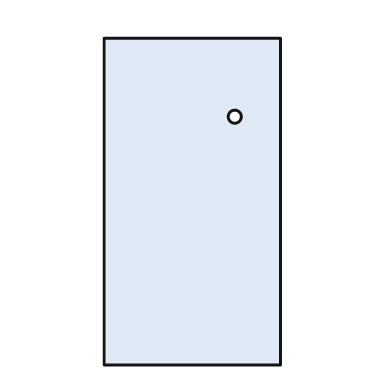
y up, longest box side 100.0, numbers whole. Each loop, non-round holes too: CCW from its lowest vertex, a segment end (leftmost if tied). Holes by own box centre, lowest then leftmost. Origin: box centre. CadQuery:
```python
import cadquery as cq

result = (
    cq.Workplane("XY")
    .moveTo(-27.0, -50.0)
    .lineTo(27.0, -50.0)
    .lineTo(27.0, 50.0)
    .lineTo(-27.0, 50.0)
    .close()
    .moveTo(13.0, 26.0)
    .circle(2.0)
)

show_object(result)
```